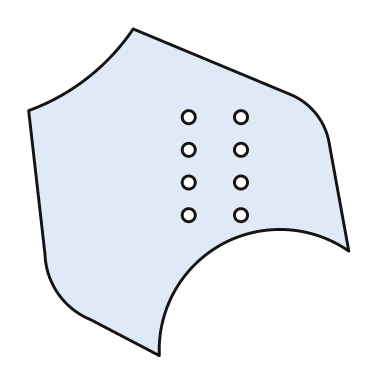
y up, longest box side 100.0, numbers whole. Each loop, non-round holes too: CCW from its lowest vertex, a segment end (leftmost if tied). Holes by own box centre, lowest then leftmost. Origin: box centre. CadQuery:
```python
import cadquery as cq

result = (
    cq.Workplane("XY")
    .moveTo(-9.0, -50.0)
    .threePointArc((10.0, -16.0), (49.0, -18.0))
    .lineTo(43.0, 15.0)
    .threePointArc((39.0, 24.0), (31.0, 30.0))
    .lineTo(-17.0, 50.0)
    .threePointArc((-31.0, 35.0), (-49.0, 25.0))
    .lineTo(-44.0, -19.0)
    .threePointArc((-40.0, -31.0), (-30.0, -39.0))
    .close()
    .moveTo(0.0, -7.0)
    .circle(2.0)
    .moveTo(16.0, -7.0)
    .circle(2.0)
    .moveTo(0.0, 3.0)
    .circle(2.0)
    .moveTo(16.0, 3.0)
    .circle(2.0)
    .moveTo(0.0, 13.0)
    .circle(2.0)
    .moveTo(16.0, 13.0)
    .circle(2.0)
    .moveTo(0.0, 23.0)
    .circle(2.0)
    .moveTo(16.0, 23.0)
    .circle(2.0)
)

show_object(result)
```